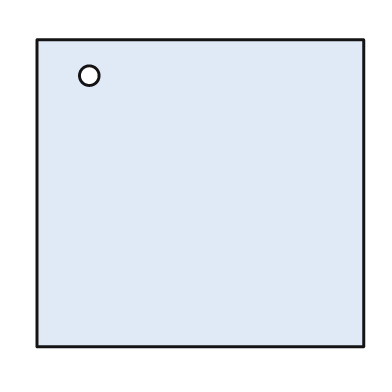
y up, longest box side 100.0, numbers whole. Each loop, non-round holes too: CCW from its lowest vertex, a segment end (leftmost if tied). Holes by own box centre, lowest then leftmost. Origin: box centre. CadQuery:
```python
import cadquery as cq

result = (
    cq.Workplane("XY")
    .moveTo(-50.0, -47.0)
    .lineTo(50.0, -47.0)
    .lineTo(50.0, 47.0)
    .lineTo(-50.0, 47.0)
    .close()
    .moveTo(-34.0, 36.0)
    .circle(3.0)
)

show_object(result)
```